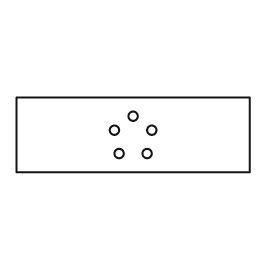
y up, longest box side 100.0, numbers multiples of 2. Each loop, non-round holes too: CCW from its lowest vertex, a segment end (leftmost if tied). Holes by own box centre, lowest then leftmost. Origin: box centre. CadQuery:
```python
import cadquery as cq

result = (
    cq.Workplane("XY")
    .moveTo(-50.0, -16.0)
    .lineTo(50.0, -16.0)
    .lineTo(50.0, 16.0)
    .lineTo(-50.0, 16.0)
    .close()
    .moveTo(-6.0, -8.0)
    .circle(2.0)
    .moveTo(6.0, -8.0)
    .circle(2.0)
    .moveTo(-8.0, 2.0)
    .circle(2.0)
    .moveTo(8.0, 2.0)
    .circle(2.0)
    .moveTo(0.0, 8.0)
    .circle(2.0)
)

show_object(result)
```